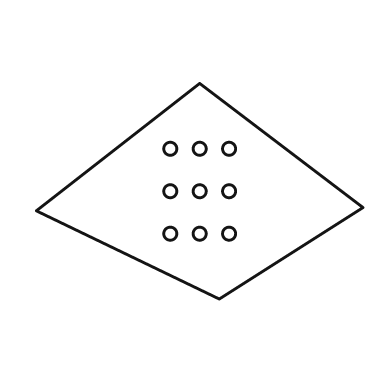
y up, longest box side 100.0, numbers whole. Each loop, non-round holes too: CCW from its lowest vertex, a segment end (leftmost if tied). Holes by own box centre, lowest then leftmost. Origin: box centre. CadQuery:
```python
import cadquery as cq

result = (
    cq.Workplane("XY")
    .moveTo(6.0, -33.0)
    .lineTo(50.0, -5.0)
    .lineTo(0.0, 33.0)
    .lineTo(-50.0, -6.0)
    .close()
    .moveTo(-9.0, -13.0)
    .circle(2.0)
    .moveTo(0.0, -13.0)
    .circle(2.0)
    .moveTo(9.0, -13.0)
    .circle(2.0)
    .moveTo(-9.0, 0.0)
    .circle(2.0)
    .moveTo(0.0, 0.0)
    .circle(2.0)
    .moveTo(9.0, 0.0)
    .circle(2.0)
    .moveTo(-9.0, 13.0)
    .circle(2.0)
    .moveTo(0.0, 13.0)
    .circle(2.0)
    .moveTo(9.0, 13.0)
    .circle(2.0)
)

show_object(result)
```